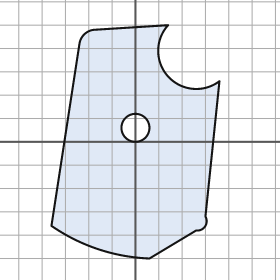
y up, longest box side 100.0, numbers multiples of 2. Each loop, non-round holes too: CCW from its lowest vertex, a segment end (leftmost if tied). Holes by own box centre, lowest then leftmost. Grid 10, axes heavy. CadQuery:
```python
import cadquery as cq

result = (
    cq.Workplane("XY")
    .moveTo(6.0, -50.0)
    .lineTo(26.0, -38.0)
    .threePointArc((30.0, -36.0), (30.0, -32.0))
    .lineTo(36.0, 26.0)
    .threePointArc((14.0, 28.0), (14.0, 50.0))
    .lineTo(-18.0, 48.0)
    .threePointArc((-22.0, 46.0), (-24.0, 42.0))
    .lineTo(-36.0, -36.0)
    .threePointArc((-16.0, -46.0), (6.0, -50.0))
    .close()
    .moveTo(0.0, 6.0)
    .circle(6.0)
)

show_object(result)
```